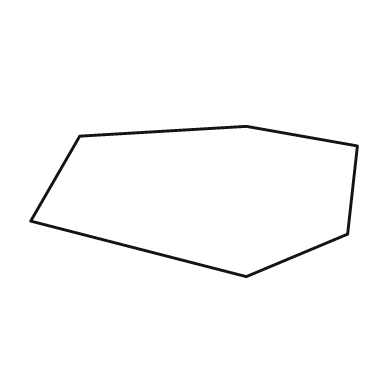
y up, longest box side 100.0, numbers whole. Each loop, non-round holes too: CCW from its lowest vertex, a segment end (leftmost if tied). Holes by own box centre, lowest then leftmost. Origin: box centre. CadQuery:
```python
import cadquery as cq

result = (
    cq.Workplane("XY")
    .moveTo(16.0, -23.0)
    .lineTo(47.0, -10.0)
    .lineTo(50.0, 17.0)
    .lineTo(16.0, 23.0)
    .lineTo(-35.0, 20.0)
    .lineTo(-50.0, -6.0)
    .close()
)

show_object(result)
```